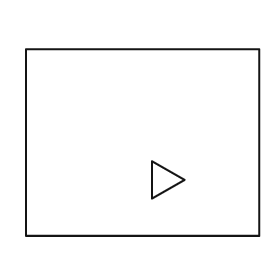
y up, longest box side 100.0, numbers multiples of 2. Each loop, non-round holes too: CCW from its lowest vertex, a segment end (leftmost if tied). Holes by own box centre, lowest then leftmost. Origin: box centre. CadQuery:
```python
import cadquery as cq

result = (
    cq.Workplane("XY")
    .moveTo(-50.0, -40.0)
    .lineTo(50.0, -40.0)
    .lineTo(50.0, 40.0)
    .lineTo(-50.0, 40.0)
    .close()
    .moveTo(4.0, -24.0)
    .lineTo(18.0, -16.0)
    .lineTo(4.0, -8.0)
    .close()
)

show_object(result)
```